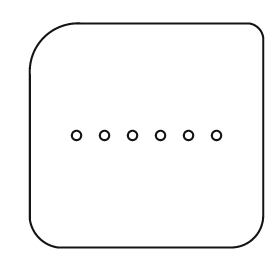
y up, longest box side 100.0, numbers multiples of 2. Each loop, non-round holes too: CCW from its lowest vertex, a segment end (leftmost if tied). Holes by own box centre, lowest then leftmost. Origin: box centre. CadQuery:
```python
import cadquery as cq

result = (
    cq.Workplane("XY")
    .moveTo(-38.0, -48.0)
    .lineTo(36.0, -48.0)
    .threePointArc((46.0, -44.0), (50.0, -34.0))
    .lineTo(50.0, 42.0)
    .threePointArc((48.0, 46.0), (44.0, 48.0))
    .lineTo(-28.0, 48.0)
    .threePointArc((-44.0, 42.0), (-50.0, 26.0))
    .lineTo(-50.0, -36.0)
    .threePointArc((-46.0, -44.0), (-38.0, -48.0))
    .close()
    .moveTo(-30.0, 0.0)
    .circle(2.0)
    .moveTo(-18.0, 0.0)
    .circle(2.0)
    .moveTo(-6.0, 0.0)
    .circle(2.0)
    .moveTo(6.0, 0.0)
    .circle(2.0)
    .moveTo(18.0, 0.0)
    .circle(2.0)
    .moveTo(30.0, 0.0)
    .circle(2.0)
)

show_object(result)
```